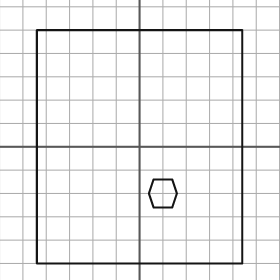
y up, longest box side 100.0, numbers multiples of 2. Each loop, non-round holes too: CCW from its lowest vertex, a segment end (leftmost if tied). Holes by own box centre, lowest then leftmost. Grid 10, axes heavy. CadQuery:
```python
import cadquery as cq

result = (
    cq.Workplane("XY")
    .moveTo(-44.0, -50.0)
    .lineTo(44.0, -50.0)
    .lineTo(44.0, 50.0)
    .lineTo(-44.0, 50.0)
    .close()
    .moveTo(6.0, -26.0)
    .lineTo(14.0, -26.0)
    .lineTo(16.0, -20.0)
    .lineTo(14.0, -14.0)
    .lineTo(6.0, -14.0)
    .lineTo(4.0, -20.0)
    .close()
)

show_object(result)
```